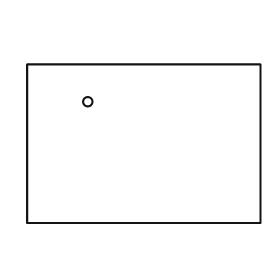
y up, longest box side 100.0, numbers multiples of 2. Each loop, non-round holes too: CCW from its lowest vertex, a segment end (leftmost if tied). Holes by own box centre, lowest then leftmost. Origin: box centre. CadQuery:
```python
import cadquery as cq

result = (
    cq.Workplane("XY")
    .moveTo(-50.0, -34.0)
    .lineTo(50.0, -34.0)
    .lineTo(50.0, 34.0)
    .lineTo(-50.0, 34.0)
    .close()
    .moveTo(-24.0, 18.0)
    .circle(2.0)
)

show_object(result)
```